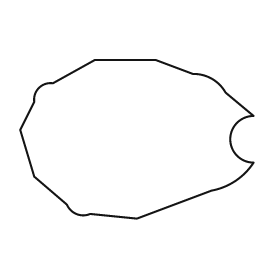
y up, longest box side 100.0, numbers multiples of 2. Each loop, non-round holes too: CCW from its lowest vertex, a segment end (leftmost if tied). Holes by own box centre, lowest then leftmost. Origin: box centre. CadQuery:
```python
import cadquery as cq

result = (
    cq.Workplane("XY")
    .moveTo(0.0, -34.0)
    .lineTo(32.0, -22.0)
    .threePointArc((42.0, -18.0), (50.0, -10.0))
    .threePointArc((40.0, 0.0), (50.0, 10.0))
    .lineTo(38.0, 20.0)
    .threePointArc((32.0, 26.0), (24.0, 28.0))
    .lineTo(8.0, 34.0)
    .lineTo(-18.0, 34.0)
    .lineTo(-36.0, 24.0)
    .threePointArc((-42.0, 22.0), (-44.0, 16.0))
    .lineTo(-50.0, 4.0)
    .lineTo(-44.0, -16.0)
    .lineTo(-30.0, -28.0)
    .threePointArc((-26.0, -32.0), (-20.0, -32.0))
    .close()
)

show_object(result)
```